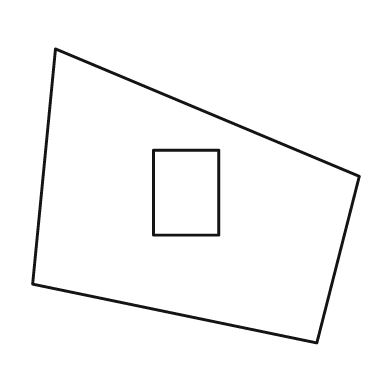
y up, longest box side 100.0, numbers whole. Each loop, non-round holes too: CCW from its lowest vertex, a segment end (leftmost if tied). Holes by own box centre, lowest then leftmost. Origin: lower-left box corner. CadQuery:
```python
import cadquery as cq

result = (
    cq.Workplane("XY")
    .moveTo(87.0, 0.0)
    .lineTo(100.0, 51.0)
    .lineTo(7.0, 90.0)
    .lineTo(0.0, 18.0)
    .close()
    .moveTo(37.0, 33.0)
    .lineTo(57.0, 33.0)
    .lineTo(57.0, 59.0)
    .lineTo(37.0, 59.0)
    .close()
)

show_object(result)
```